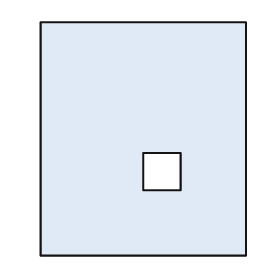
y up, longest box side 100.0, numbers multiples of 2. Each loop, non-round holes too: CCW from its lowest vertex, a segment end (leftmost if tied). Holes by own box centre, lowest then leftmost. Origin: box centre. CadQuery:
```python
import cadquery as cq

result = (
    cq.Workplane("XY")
    .moveTo(-44.0, -50.0)
    .lineTo(44.0, -50.0)
    .lineTo(44.0, 50.0)
    .lineTo(-44.0, 50.0)
    .close()
    .moveTo(0.0, -22.0)
    .lineTo(16.0, -22.0)
    .lineTo(16.0, -6.0)
    .lineTo(0.0, -6.0)
    .close()
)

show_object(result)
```